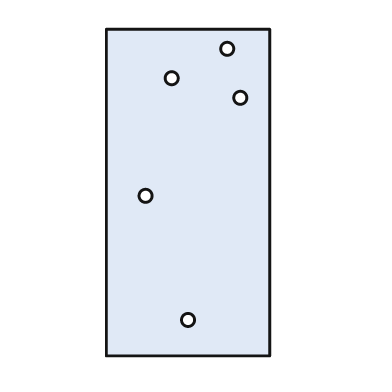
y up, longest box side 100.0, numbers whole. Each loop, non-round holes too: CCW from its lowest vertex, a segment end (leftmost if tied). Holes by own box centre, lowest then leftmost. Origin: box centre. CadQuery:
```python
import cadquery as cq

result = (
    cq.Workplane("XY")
    .moveTo(-25.0, -50.0)
    .lineTo(25.0, -50.0)
    .lineTo(25.0, 50.0)
    .lineTo(-25.0, 50.0)
    .close()
    .moveTo(0.0, -39.0)
    .circle(2.0)
    .moveTo(-13.0, -1.0)
    .circle(2.0)
    .moveTo(16.0, 29.0)
    .circle(2.0)
    .moveTo(-5.0, 35.0)
    .circle(2.0)
    .moveTo(12.0, 44.0)
    .circle(2.0)
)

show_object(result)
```